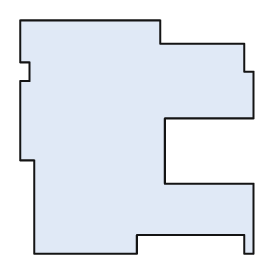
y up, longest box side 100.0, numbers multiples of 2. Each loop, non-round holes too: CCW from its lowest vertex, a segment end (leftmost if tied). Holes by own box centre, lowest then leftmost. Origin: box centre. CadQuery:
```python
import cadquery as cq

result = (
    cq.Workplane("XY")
    .moveTo(-44.0, -50.0)
    .lineTo(0.0, -50.0)
    .lineTo(0.0, -42.0)
    .lineTo(46.0, -42.0)
    .lineTo(46.0, -50.0)
    .lineTo(50.0, -50.0)
    .lineTo(50.0, -20.0)
    .lineTo(12.0, -20.0)
    .lineTo(12.0, 8.0)
    .lineTo(50.0, 8.0)
    .lineTo(50.0, 28.0)
    .lineTo(46.0, 28.0)
    .lineTo(46.0, 40.0)
    .lineTo(10.0, 40.0)
    .lineTo(10.0, 50.0)
    .lineTo(-50.0, 50.0)
    .lineTo(-50.0, 32.0)
    .lineTo(-46.0, 32.0)
    .lineTo(-46.0, 24.0)
    .lineTo(-50.0, 24.0)
    .lineTo(-50.0, -10.0)
    .lineTo(-44.0, -10.0)
    .close()
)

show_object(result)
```